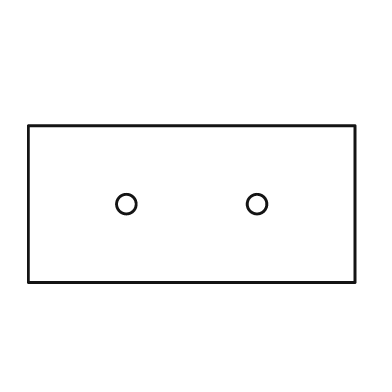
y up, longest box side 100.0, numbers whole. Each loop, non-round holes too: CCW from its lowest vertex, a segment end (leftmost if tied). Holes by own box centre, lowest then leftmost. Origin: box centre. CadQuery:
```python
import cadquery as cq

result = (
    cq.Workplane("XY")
    .moveTo(-50.0, -24.0)
    .lineTo(50.0, -24.0)
    .lineTo(50.0, 24.0)
    .lineTo(-50.0, 24.0)
    .close()
    .moveTo(-20.0, 0.0)
    .circle(3.0)
    .moveTo(20.0, 0.0)
    .circle(3.0)
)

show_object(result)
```